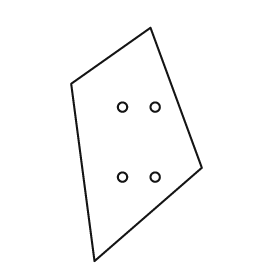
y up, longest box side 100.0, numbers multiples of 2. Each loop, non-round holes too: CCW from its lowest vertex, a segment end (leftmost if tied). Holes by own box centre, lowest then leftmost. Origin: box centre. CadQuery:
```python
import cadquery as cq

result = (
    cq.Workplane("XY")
    .moveTo(-18.0, -50.0)
    .lineTo(28.0, -10.0)
    .lineTo(6.0, 50.0)
    .lineTo(-28.0, 26.0)
    .close()
    .moveTo(-6.0, -14.0)
    .circle(2.0)
    .moveTo(8.0, -14.0)
    .circle(2.0)
    .moveTo(-6.0, 16.0)
    .circle(2.0)
    .moveTo(8.0, 16.0)
    .circle(2.0)
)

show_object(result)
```